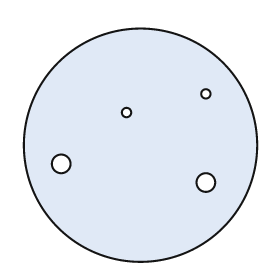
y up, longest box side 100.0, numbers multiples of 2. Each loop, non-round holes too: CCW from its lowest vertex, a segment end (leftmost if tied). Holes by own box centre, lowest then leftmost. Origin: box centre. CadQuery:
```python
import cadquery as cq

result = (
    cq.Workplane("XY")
    .moveTo(0.0, 0.0)
    .circle(50.0)
    .moveTo(28.0, -16.0)
    .circle(4.0)
    .moveTo(-34.0, -8.0)
    .circle(4.0)
    .moveTo(-6.0, 14.0)
    .circle(2.0)
    .moveTo(28.0, 22.0)
    .circle(2.0)
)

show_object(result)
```